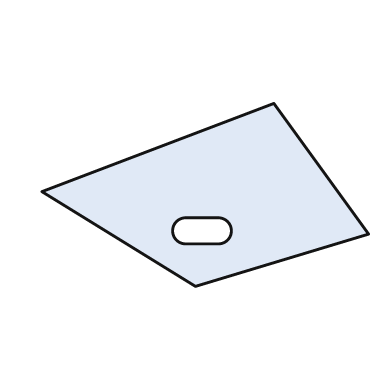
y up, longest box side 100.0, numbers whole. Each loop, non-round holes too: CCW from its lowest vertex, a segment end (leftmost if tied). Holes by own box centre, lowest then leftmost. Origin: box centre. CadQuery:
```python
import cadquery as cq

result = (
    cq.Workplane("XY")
    .moveTo(-3.0, -28.0)
    .lineTo(50.0, -12.0)
    .lineTo(21.0, 28.0)
    .lineTo(-50.0, 1.0)
    .close()
    .moveTo(-6.0, -15.0)
    .lineTo(4.0, -15.0)
    .threePointArc((8.0, -11.0), (4.0, -7.0))
    .lineTo(-6.0, -7.0)
    .threePointArc((-10.0, -11.0), (-6.0, -15.0))
    .close()
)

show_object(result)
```